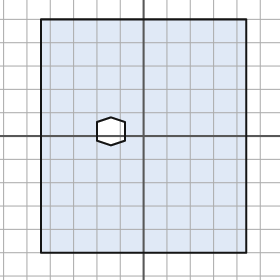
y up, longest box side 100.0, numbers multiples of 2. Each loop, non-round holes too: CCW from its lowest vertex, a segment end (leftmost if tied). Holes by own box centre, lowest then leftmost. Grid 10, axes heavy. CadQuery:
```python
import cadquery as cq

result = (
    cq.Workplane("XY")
    .moveTo(-44.0, -50.0)
    .lineTo(44.0, -50.0)
    .lineTo(44.0, 50.0)
    .lineTo(-44.0, 50.0)
    .close()
    .moveTo(-14.0, -4.0)
    .lineTo(-8.0, -2.0)
    .lineTo(-8.0, 6.0)
    .lineTo(-14.0, 8.0)
    .lineTo(-20.0, 6.0)
    .lineTo(-20.0, -2.0)
    .close()
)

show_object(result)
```